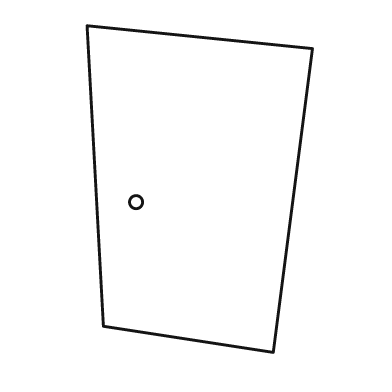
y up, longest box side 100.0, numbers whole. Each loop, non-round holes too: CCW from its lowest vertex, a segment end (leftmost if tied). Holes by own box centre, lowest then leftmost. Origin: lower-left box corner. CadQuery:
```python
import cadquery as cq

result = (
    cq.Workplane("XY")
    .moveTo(57.0, 0.0)
    .lineTo(69.0, 93.0)
    .lineTo(0.0, 100.0)
    .lineTo(5.0, 8.0)
    .close()
    .moveTo(15.0, 46.0)
    .circle(2.0)
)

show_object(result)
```